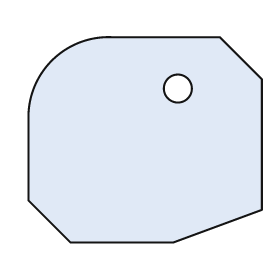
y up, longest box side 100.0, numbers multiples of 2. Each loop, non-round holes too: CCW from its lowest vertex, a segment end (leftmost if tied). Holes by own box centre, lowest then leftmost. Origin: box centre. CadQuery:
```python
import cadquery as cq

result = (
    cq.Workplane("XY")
    .moveTo(-32.0, -44.0)
    .lineTo(12.0, -44.0)
    .lineTo(50.0, -30.0)
    .lineTo(50.0, 26.0)
    .lineTo(32.0, 44.0)
    .lineTo(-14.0, 44.0)
    .threePointArc((-40.0, 34.0), (-50.0, 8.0))
    .lineTo(-50.0, -26.0)
    .close()
    .moveTo(14.0, 22.0)
    .circle(6.0)
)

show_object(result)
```